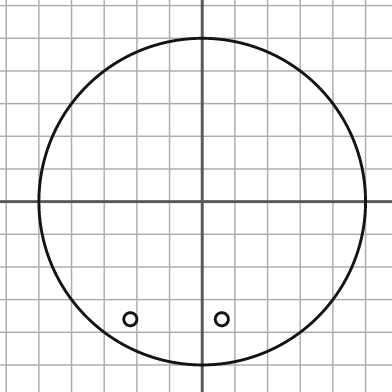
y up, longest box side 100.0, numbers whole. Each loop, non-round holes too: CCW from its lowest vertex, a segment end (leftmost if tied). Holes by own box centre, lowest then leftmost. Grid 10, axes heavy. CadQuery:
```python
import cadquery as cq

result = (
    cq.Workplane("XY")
    .moveTo(0.0, 0.0)
    .circle(50.0)
    .moveTo(-22.0, -36.0)
    .circle(2.0)
    .moveTo(6.0, -36.0)
    .circle(2.0)
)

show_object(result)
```